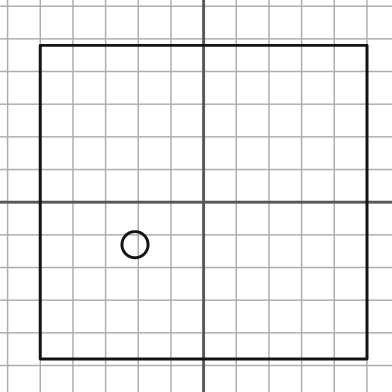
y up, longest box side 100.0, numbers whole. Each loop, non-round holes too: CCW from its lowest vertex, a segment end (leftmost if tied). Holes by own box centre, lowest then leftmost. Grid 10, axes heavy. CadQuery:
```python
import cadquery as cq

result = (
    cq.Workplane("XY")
    .moveTo(-50.0, -48.0)
    .lineTo(50.0, -48.0)
    .lineTo(50.0, 48.0)
    .lineTo(-50.0, 48.0)
    .close()
    .moveTo(-21.0, -13.0)
    .circle(4.0)
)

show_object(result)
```